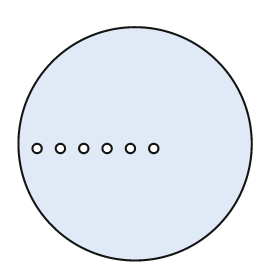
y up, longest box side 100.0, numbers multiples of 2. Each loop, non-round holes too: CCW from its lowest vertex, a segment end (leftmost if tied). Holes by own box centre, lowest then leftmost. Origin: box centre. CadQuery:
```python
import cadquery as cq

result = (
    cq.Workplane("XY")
    .moveTo(0.0, 0.0)
    .circle(50.0)
    .moveTo(-42.0, -2.0)
    .circle(2.0)
    .moveTo(-32.0, -2.0)
    .circle(2.0)
    .moveTo(-22.0, -2.0)
    .circle(2.0)
    .moveTo(-12.0, -2.0)
    .circle(2.0)
    .moveTo(-2.0, -2.0)
    .circle(2.0)
    .moveTo(8.0, -2.0)
    .circle(2.0)
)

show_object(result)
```